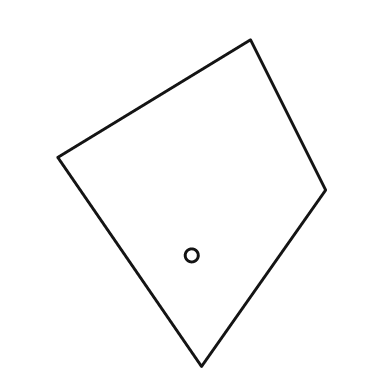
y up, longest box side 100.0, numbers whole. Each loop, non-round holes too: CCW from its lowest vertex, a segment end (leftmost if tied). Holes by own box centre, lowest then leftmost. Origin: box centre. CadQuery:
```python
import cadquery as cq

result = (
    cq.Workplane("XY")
    .moveTo(3.0, -50.0)
    .lineTo(41.0, 4.0)
    .lineTo(18.0, 50.0)
    .lineTo(-41.0, 14.0)
    .close()
    .moveTo(0.0, -16.0)
    .circle(2.0)
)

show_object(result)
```